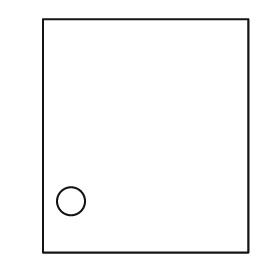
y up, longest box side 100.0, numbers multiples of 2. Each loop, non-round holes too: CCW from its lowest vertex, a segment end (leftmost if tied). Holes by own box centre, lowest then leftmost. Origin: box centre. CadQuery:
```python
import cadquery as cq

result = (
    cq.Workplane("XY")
    .moveTo(-44.0, -50.0)
    .lineTo(44.0, -50.0)
    .lineTo(44.0, 50.0)
    .lineTo(-44.0, 50.0)
    .close()
    .moveTo(-32.0, -28.0)
    .circle(6.0)
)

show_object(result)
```